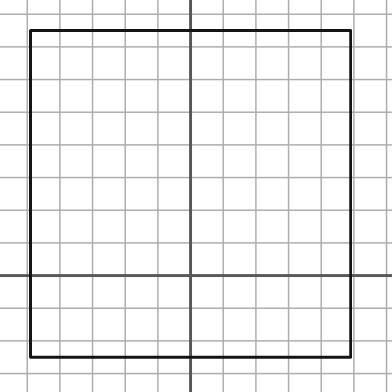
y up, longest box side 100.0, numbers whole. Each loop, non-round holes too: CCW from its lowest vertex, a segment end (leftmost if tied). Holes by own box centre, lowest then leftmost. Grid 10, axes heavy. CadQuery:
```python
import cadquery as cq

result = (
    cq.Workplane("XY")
    .moveTo(-49.0, -25.0)
    .lineTo(49.0, -25.0)
    .lineTo(49.0, 75.0)
    .lineTo(-49.0, 75.0)
    .close()
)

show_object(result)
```